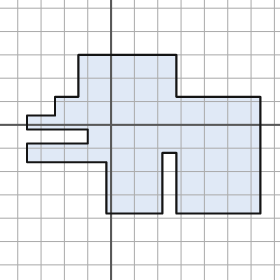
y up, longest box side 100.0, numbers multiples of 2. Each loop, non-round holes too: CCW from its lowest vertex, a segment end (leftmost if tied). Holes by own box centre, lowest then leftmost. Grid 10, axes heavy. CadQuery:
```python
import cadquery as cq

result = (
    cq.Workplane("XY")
    .moveTo(-2.0, -38.0)
    .lineTo(22.0, -38.0)
    .lineTo(22.0, -12.0)
    .lineTo(28.0, -12.0)
    .lineTo(28.0, -38.0)
    .lineTo(64.0, -38.0)
    .lineTo(64.0, 12.0)
    .lineTo(28.0, 12.0)
    .lineTo(28.0, 30.0)
    .lineTo(-14.0, 30.0)
    .lineTo(-14.0, 12.0)
    .lineTo(-24.0, 12.0)
    .lineTo(-24.0, 4.0)
    .lineTo(-36.0, 4.0)
    .lineTo(-36.0, -2.0)
    .lineTo(-10.0, -2.0)
    .lineTo(-10.0, -8.0)
    .lineTo(-36.0, -8.0)
    .lineTo(-36.0, -16.0)
    .lineTo(-2.0, -16.0)
    .close()
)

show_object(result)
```